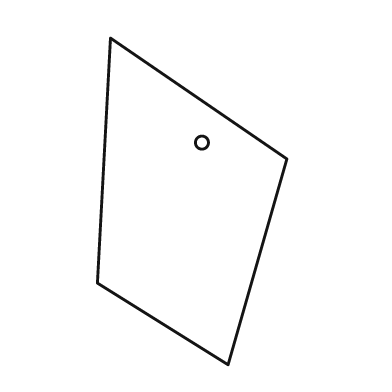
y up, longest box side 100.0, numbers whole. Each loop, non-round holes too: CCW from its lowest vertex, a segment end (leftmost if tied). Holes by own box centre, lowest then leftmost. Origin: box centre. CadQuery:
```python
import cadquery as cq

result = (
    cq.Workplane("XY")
    .moveTo(11.0, -50.0)
    .lineTo(29.0, 13.0)
    .lineTo(-25.0, 50.0)
    .lineTo(-29.0, -25.0)
    .close()
    .moveTo(3.0, 18.0)
    .circle(2.0)
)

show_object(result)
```